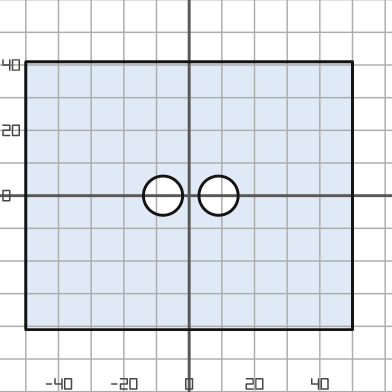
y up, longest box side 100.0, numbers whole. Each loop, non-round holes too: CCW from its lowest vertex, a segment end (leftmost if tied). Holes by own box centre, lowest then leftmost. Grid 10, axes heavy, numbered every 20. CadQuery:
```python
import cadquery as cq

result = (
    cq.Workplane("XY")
    .moveTo(-50.0, -41.0)
    .lineTo(50.0, -41.0)
    .lineTo(50.0, 41.0)
    .lineTo(-50.0, 41.0)
    .close()
    .moveTo(-8.0, 0.0)
    .circle(6.0)
    .moveTo(9.0, 0.0)
    .circle(6.0)
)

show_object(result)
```